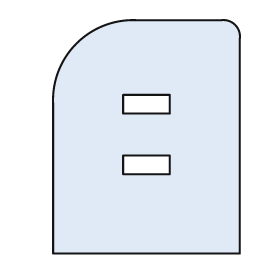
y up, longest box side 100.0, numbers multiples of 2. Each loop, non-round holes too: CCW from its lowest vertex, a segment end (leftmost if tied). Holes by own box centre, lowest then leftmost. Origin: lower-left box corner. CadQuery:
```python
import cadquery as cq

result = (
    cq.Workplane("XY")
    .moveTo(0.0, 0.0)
    .lineTo(80.0, 0.0)
    .lineTo(80.0, 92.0)
    .threePointArc((78.0, 98.0), (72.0, 100.0))
    .lineTo(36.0, 100.0)
    .threePointArc((10.0, 90.0), (0.0, 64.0))
    .close()
    .moveTo(30.0, 34.0)
    .lineTo(50.0, 34.0)
    .lineTo(50.0, 42.0)
    .lineTo(30.0, 42.0)
    .close()
    .moveTo(30.0, 60.0)
    .lineTo(50.0, 60.0)
    .lineTo(50.0, 68.0)
    .lineTo(30.0, 68.0)
    .close()
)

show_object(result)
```